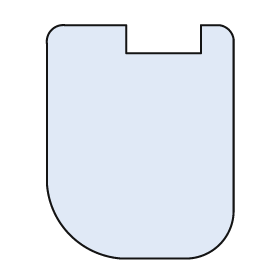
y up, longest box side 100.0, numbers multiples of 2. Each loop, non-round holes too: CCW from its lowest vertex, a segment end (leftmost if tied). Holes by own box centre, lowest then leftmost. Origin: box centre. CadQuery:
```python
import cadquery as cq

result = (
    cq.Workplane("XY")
    .moveTo(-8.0, -50.0)
    .lineTo(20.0, -50.0)
    .threePointArc((34.0, -44.0), (40.0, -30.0))
    .lineTo(40.0, 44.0)
    .threePointArc((38.0, 48.0), (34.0, 50.0))
    .lineTo(26.0, 50.0)
    .lineTo(26.0, 38.0)
    .lineTo(-6.0, 38.0)
    .lineTo(-6.0, 50.0)
    .lineTo(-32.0, 50.0)
    .threePointArc((-38.0, 48.0), (-40.0, 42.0))
    .lineTo(-40.0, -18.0)
    .threePointArc((-30.0, -40.0), (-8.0, -50.0))
    .close()
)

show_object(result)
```